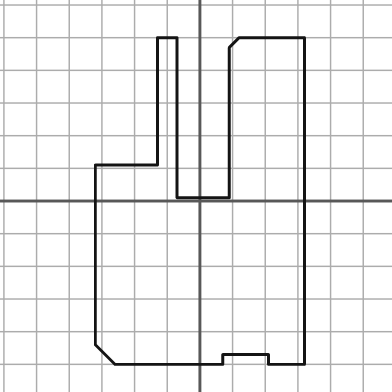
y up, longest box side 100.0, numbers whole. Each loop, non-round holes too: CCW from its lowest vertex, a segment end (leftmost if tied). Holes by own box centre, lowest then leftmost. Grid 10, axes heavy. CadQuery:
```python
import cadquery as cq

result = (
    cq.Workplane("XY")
    .moveTo(-26.0, -50.0)
    .lineTo(7.0, -50.0)
    .lineTo(7.0, -47.0)
    .lineTo(21.0, -47.0)
    .lineTo(21.0, -50.0)
    .lineTo(32.0, -50.0)
    .lineTo(32.0, 50.0)
    .lineTo(12.0, 50.0)
    .lineTo(9.0, 47.0)
    .lineTo(9.0, 1.0)
    .lineTo(-7.0, 1.0)
    .lineTo(-7.0, 50.0)
    .lineTo(-13.0, 50.0)
    .lineTo(-13.0, 11.0)
    .lineTo(-32.0, 11.0)
    .lineTo(-32.0, -44.0)
    .close()
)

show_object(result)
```